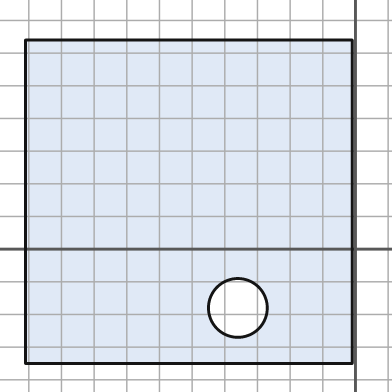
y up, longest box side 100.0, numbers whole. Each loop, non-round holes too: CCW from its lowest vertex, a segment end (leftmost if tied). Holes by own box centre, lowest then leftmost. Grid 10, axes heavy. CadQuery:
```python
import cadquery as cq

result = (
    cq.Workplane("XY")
    .moveTo(-101.0, -35.0)
    .lineTo(-1.0, -35.0)
    .lineTo(-1.0, 64.0)
    .lineTo(-101.0, 64.0)
    .close()
    .moveTo(-36.0, -18.0)
    .circle(9.0)
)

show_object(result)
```